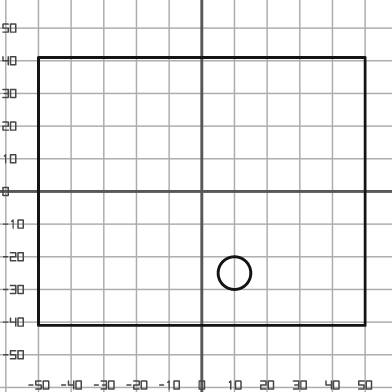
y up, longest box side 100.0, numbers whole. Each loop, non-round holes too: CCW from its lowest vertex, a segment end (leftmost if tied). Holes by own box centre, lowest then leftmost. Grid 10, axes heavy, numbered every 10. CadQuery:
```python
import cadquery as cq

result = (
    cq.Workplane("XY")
    .moveTo(-50.0, -41.0)
    .lineTo(50.0, -41.0)
    .lineTo(50.0, 41.0)
    .lineTo(-50.0, 41.0)
    .close()
    .moveTo(10.0, -25.0)
    .circle(5.0)
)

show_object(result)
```